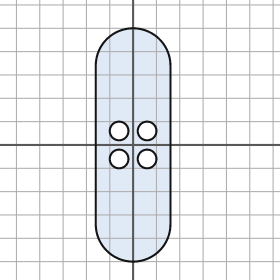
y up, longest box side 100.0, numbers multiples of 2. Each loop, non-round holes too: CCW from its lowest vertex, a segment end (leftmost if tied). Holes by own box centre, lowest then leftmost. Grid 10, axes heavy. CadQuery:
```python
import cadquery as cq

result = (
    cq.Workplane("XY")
    .moveTo(-16.0, -34.0)
    .threePointArc((0.0, -50.0), (16.0, -34.0))
    .lineTo(16.0, 34.0)
    .threePointArc((0.0, 50.0), (-16.0, 34.0))
    .close()
    .moveTo(-6.0, -6.0)
    .circle(4.0)
    .moveTo(6.0, -6.0)
    .circle(4.0)
    .moveTo(-6.0, 6.0)
    .circle(4.0)
    .moveTo(6.0, 6.0)
    .circle(4.0)
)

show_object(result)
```